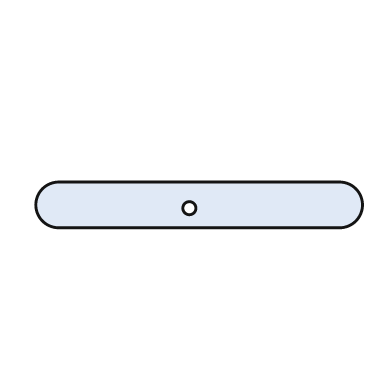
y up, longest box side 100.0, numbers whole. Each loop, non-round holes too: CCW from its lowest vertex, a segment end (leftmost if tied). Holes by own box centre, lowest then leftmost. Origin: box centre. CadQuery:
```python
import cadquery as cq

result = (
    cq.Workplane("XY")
    .moveTo(-43.0, -7.0)
    .lineTo(43.0, -7.0)
    .threePointArc((50.0, 0.0), (43.0, 7.0))
    .lineTo(-43.0, 7.0)
    .threePointArc((-50.0, 0.0), (-43.0, -7.0))
    .close()
    .moveTo(-3.0, -1.0)
    .circle(2.0)
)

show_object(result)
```